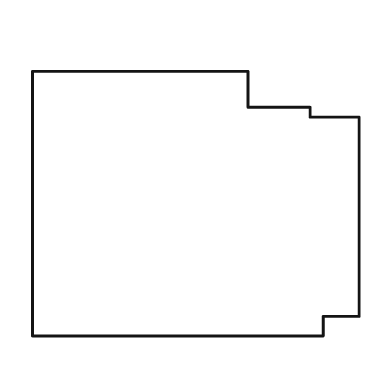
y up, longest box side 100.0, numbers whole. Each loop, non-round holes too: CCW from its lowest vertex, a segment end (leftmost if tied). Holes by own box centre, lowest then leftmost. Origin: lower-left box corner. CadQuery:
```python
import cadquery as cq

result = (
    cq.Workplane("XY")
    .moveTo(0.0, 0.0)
    .lineTo(89.0, 0.0)
    .lineTo(89.0, 6.0)
    .lineTo(100.0, 6.0)
    .lineTo(100.0, 67.0)
    .lineTo(85.0, 67.0)
    .lineTo(85.0, 70.0)
    .lineTo(66.0, 70.0)
    .lineTo(66.0, 81.0)
    .lineTo(0.0, 81.0)
    .close()
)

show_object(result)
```